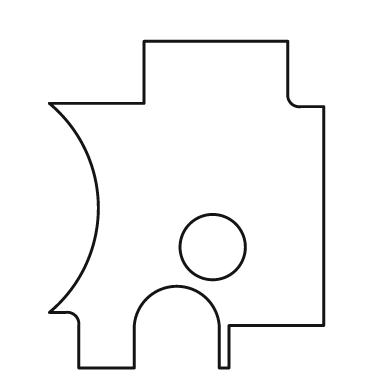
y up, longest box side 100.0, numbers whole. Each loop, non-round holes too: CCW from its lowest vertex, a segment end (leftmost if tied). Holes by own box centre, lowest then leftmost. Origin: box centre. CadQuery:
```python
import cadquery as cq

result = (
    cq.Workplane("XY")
    .moveTo(-33.0, -50.0)
    .lineTo(-16.0, -50.0)
    .lineTo(-16.0, -37.0)
    .threePointArc((-3.0, -25.0), (10.0, -37.0))
    .lineTo(10.0, -50.0)
    .lineTo(13.0, -50.0)
    .lineTo(13.0, -37.0)
    .lineTo(42.0, -37.0)
    .lineTo(42.0, 30.0)
    .lineTo(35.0, 30.0)
    .threePointArc((32.0, 31.0), (31.0, 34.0))
    .lineTo(31.0, 50.0)
    .lineTo(-13.0, 50.0)
    .lineTo(-13.0, 31.0)
    .lineTo(-42.0, 31.0)
    .threePointArc((-27.0, -1.0), (-42.0, -33.0))
    .lineTo(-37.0, -33.0)
    .threePointArc((-34.0, -34.0), (-33.0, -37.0))
    .close()
    .moveTo(8.0, -13.0)
    .circle(10.0)
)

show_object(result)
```